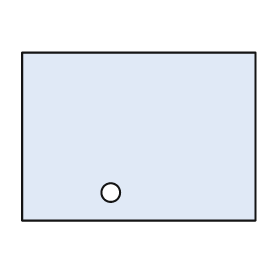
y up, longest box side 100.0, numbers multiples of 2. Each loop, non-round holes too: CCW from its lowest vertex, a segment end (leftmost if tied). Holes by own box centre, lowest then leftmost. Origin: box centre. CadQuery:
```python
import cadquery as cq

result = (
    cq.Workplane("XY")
    .moveTo(-50.0, -36.0)
    .lineTo(50.0, -36.0)
    .lineTo(50.0, 36.0)
    .lineTo(-50.0, 36.0)
    .close()
    .moveTo(-12.0, -24.0)
    .circle(4.0)
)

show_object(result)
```